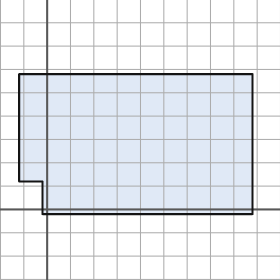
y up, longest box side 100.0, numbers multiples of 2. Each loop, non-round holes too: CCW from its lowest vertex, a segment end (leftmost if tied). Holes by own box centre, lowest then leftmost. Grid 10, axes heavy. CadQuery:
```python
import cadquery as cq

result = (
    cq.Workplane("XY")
    .moveTo(-2.0, -2.0)
    .lineTo(88.0, -2.0)
    .lineTo(88.0, 58.0)
    .lineTo(-12.0, 58.0)
    .lineTo(-12.0, 12.0)
    .lineTo(-2.0, 12.0)
    .close()
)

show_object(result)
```